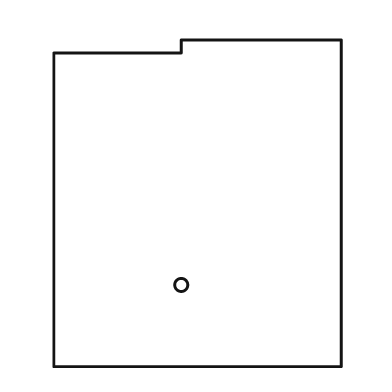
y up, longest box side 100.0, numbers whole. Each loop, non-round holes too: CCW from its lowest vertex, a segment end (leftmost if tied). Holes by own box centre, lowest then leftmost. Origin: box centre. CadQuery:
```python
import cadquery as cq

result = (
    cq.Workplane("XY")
    .moveTo(-44.0, -50.0)
    .lineTo(44.0, -50.0)
    .lineTo(44.0, 50.0)
    .lineTo(-5.0, 50.0)
    .lineTo(-5.0, 46.0)
    .lineTo(-44.0, 46.0)
    .close()
    .moveTo(-5.0, -25.0)
    .circle(2.0)
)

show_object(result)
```